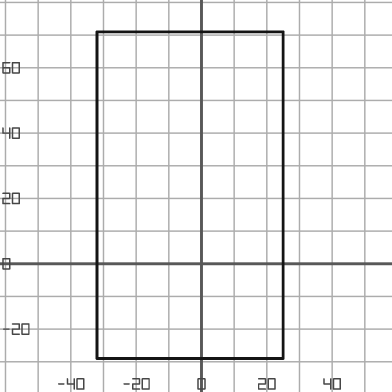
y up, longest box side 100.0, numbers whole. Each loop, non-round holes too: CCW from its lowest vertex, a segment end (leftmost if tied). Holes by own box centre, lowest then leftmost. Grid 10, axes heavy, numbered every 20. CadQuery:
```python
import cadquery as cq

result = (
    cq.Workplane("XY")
    .moveTo(-32.0, -29.0)
    .lineTo(25.0, -29.0)
    .lineTo(25.0, 71.0)
    .lineTo(-32.0, 71.0)
    .close()
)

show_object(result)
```